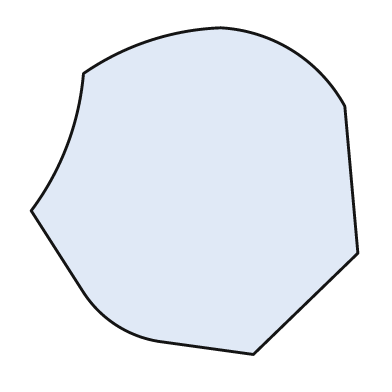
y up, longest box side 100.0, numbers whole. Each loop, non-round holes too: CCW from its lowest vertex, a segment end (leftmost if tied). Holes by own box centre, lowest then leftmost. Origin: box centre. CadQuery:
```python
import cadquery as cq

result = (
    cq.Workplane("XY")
    .moveTo(18.0, -50.0)
    .lineTo(50.0, -19.0)
    .lineTo(46.0, 26.0)
    .threePointArc((30.0, 43.0), (8.0, 50.0))
    .threePointArc((-14.0, 46.0), (-34.0, 36.0))
    .threePointArc((-39.0, 14.0), (-50.0, -6.0))
    .lineTo(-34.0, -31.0)
    .threePointArc((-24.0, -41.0), (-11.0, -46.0))
    .close()
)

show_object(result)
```